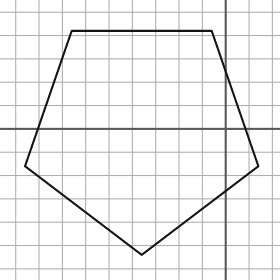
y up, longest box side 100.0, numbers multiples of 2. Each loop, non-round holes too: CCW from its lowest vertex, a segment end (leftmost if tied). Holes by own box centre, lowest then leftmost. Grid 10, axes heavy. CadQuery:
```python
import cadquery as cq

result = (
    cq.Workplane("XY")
    .moveTo(-36.0, -54.0)
    .lineTo(14.0, -16.0)
    .lineTo(-6.0, 42.0)
    .lineTo(-66.0, 42.0)
    .lineTo(-86.0, -16.0)
    .close()
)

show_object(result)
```